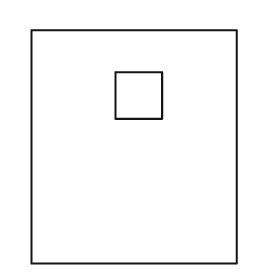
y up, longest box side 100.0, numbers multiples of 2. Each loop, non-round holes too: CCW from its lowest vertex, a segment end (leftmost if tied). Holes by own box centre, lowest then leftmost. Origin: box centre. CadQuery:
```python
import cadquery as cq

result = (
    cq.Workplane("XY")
    .moveTo(-44.0, -50.0)
    .lineTo(44.0, -50.0)
    .lineTo(44.0, 50.0)
    .lineTo(-44.0, 50.0)
    .close()
    .moveTo(-8.0, 12.0)
    .lineTo(12.0, 12.0)
    .lineTo(12.0, 32.0)
    .lineTo(-8.0, 32.0)
    .close()
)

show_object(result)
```